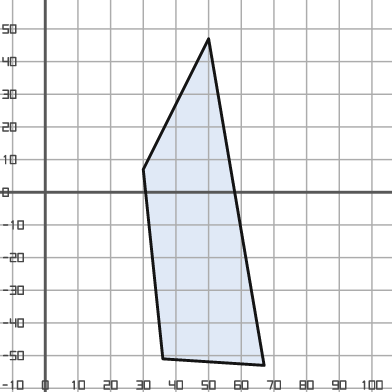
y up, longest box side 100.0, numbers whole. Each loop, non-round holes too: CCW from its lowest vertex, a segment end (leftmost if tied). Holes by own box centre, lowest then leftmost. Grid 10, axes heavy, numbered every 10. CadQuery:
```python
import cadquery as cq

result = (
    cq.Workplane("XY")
    .moveTo(67.0, -53.0)
    .lineTo(50.0, 47.0)
    .lineTo(30.0, 7.0)
    .lineTo(36.0, -51.0)
    .close()
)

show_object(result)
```